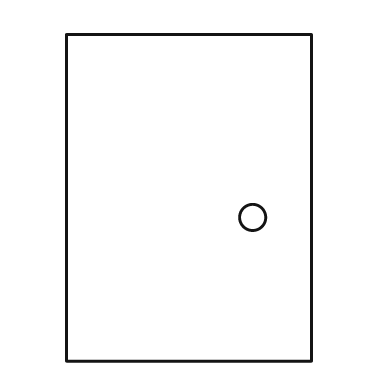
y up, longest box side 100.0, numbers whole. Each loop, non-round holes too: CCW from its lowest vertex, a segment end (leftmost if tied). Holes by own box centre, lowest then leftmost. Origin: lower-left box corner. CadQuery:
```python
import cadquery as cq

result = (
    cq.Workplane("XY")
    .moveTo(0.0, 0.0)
    .lineTo(75.0, 0.0)
    .lineTo(75.0, 100.0)
    .lineTo(0.0, 100.0)
    .close()
    .moveTo(57.0, 44.0)
    .circle(4.0)
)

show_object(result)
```